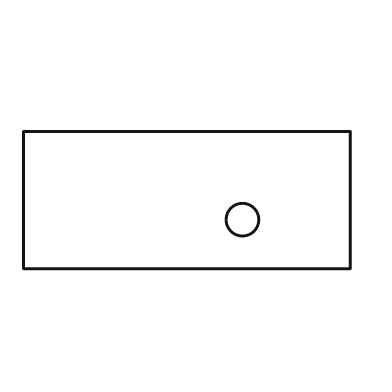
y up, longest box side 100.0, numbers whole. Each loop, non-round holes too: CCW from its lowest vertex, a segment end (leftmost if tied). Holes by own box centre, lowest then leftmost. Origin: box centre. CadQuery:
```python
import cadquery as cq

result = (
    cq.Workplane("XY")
    .moveTo(-50.0, -21.0)
    .lineTo(50.0, -21.0)
    .lineTo(50.0, 21.0)
    .lineTo(-50.0, 21.0)
    .close()
    .moveTo(17.0, -6.0)
    .circle(5.0)
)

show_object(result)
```